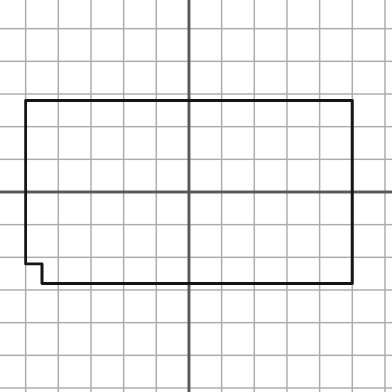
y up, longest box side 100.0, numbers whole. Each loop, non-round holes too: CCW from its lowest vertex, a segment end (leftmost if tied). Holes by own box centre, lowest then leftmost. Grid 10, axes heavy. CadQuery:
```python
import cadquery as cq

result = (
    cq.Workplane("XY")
    .moveTo(-45.0, -28.0)
    .lineTo(50.0, -28.0)
    .lineTo(50.0, 28.0)
    .lineTo(-50.0, 28.0)
    .lineTo(-50.0, -22.0)
    .lineTo(-45.0, -22.0)
    .close()
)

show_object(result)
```